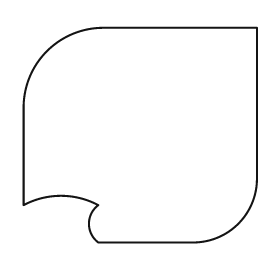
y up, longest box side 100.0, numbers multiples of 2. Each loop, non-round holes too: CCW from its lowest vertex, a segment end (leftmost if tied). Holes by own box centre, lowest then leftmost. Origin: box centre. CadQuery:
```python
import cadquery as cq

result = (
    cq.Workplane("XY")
    .moveTo(-18.0, -46.0)
    .lineTo(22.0, -46.0)
    .threePointArc((42.0, -38.0), (50.0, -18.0))
    .lineTo(50.0, 46.0)
    .lineTo(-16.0, 46.0)
    .threePointArc((-40.0, 36.0), (-50.0, 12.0))
    .lineTo(-50.0, -30.0)
    .threePointArc((-34.0, -26.0), (-18.0, -30.0))
    .threePointArc((-22.0, -38.0), (-18.0, -46.0))
    .close()
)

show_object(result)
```